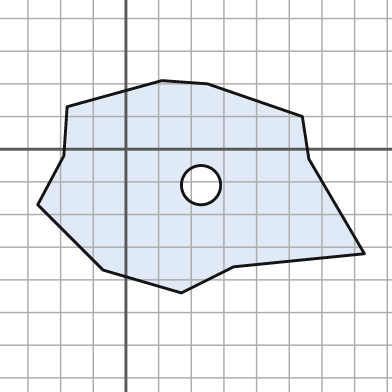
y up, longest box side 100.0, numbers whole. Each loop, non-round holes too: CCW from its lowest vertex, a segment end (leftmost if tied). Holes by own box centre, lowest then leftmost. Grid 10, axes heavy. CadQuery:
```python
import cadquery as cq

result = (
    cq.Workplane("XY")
    .moveTo(17.0, -44.0)
    .lineTo(33.0, -36.0)
    .lineTo(73.0, -32.0)
    .lineTo(56.0, -3.0)
    .lineTo(54.0, 10.0)
    .lineTo(25.0, 20.0)
    .lineTo(11.0, 21.0)
    .lineTo(-18.0, 13.0)
    .lineTo(-19.0, -2.0)
    .lineTo(-27.0, -17.0)
    .lineTo(-7.0, -37.0)
    .close()
    .moveTo(23.0, -11.0)
    .circle(6.0)
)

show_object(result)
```